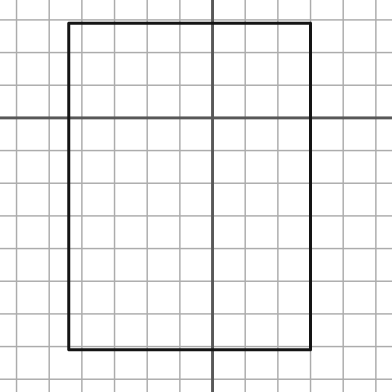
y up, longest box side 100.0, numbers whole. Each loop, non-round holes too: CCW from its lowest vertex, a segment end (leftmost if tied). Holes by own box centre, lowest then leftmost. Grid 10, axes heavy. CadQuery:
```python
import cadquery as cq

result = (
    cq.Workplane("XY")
    .moveTo(-44.0, -71.0)
    .lineTo(30.0, -71.0)
    .lineTo(30.0, 29.0)
    .lineTo(-44.0, 29.0)
    .close()
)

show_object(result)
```